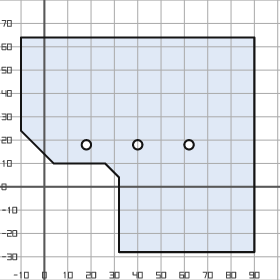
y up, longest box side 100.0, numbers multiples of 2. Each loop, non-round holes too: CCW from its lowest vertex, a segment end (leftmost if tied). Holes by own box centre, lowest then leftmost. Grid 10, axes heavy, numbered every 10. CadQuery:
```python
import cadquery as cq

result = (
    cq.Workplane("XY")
    .moveTo(32.0, -28.0)
    .lineTo(90.0, -28.0)
    .lineTo(90.0, 64.0)
    .lineTo(-10.0, 64.0)
    .lineTo(-10.0, 24.0)
    .lineTo(4.0, 10.0)
    .lineTo(26.0, 10.0)
    .lineTo(32.0, 4.0)
    .close()
    .moveTo(18.0, 18.0)
    .circle(2.0)
    .moveTo(40.0, 18.0)
    .circle(2.0)
    .moveTo(62.0, 18.0)
    .circle(2.0)
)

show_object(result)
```